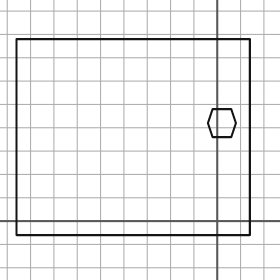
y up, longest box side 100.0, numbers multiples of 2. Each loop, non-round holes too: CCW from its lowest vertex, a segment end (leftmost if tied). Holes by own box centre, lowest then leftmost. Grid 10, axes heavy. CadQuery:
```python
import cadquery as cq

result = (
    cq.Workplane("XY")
    .moveTo(-86.0, -6.0)
    .lineTo(14.0, -6.0)
    .lineTo(14.0, 78.0)
    .lineTo(-86.0, 78.0)
    .close()
    .moveTo(-2.0, 36.0)
    .lineTo(6.0, 36.0)
    .lineTo(8.0, 42.0)
    .lineTo(6.0, 48.0)
    .lineTo(-2.0, 48.0)
    .lineTo(-4.0, 42.0)
    .close()
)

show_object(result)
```